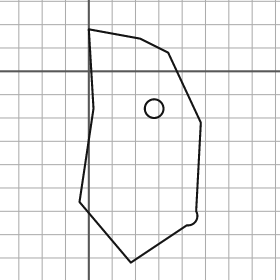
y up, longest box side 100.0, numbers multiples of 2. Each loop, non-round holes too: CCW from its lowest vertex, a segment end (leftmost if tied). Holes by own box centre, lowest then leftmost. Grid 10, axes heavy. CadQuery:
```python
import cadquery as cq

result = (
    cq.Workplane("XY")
    .moveTo(18.0, -82.0)
    .lineTo(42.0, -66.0)
    .threePointArc((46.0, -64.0), (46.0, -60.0))
    .lineTo(48.0, -22.0)
    .lineTo(34.0, 8.0)
    .lineTo(22.0, 14.0)
    .lineTo(0.0, 18.0)
    .lineTo(2.0, -16.0)
    .lineTo(-4.0, -56.0)
    .close()
    .moveTo(28.0, -16.0)
    .circle(4.0)
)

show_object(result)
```